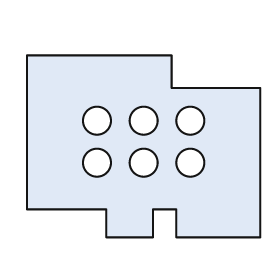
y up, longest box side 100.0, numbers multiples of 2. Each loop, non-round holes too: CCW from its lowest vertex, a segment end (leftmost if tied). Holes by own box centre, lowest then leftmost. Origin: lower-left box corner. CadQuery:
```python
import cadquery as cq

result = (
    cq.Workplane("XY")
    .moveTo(34.0, 0.0)
    .lineTo(54.0, 0.0)
    .lineTo(54.0, 12.0)
    .lineTo(64.0, 12.0)
    .lineTo(64.0, 0.0)
    .lineTo(100.0, 0.0)
    .lineTo(100.0, 64.0)
    .lineTo(62.0, 64.0)
    .lineTo(62.0, 78.0)
    .lineTo(0.0, 78.0)
    .lineTo(0.0, 12.0)
    .lineTo(34.0, 12.0)
    .close()
    .moveTo(30.0, 32.0)
    .circle(6.0)
    .moveTo(50.0, 32.0)
    .circle(6.0)
    .moveTo(70.0, 32.0)
    .circle(6.0)
    .moveTo(30.0, 50.0)
    .circle(6.0)
    .moveTo(50.0, 50.0)
    .circle(6.0)
    .moveTo(70.0, 50.0)
    .circle(6.0)
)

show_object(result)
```